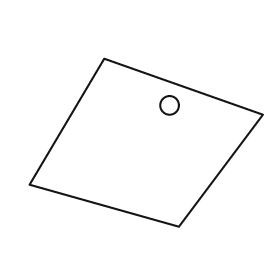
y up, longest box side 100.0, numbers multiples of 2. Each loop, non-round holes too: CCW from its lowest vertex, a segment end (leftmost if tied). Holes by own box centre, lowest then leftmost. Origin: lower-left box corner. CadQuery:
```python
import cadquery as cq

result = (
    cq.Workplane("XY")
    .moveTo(64.0, 0.0)
    .lineTo(100.0, 48.0)
    .lineTo(32.0, 72.0)
    .lineTo(0.0, 18.0)
    .close()
    .moveTo(60.0, 52.0)
    .circle(4.0)
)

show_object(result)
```